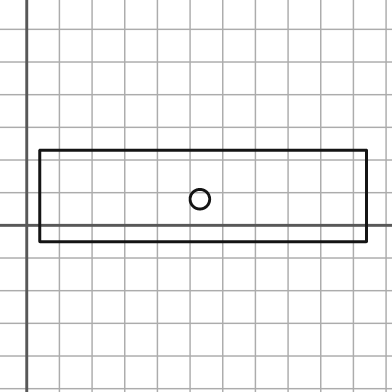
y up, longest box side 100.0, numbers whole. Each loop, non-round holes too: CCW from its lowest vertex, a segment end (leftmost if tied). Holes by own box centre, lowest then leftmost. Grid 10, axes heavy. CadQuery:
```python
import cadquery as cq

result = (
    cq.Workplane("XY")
    .moveTo(4.0, -5.0)
    .lineTo(104.0, -5.0)
    .lineTo(104.0, 23.0)
    .lineTo(4.0, 23.0)
    .close()
    .moveTo(53.0, 8.0)
    .circle(3.0)
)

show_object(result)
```